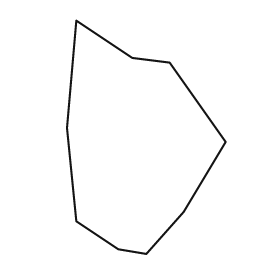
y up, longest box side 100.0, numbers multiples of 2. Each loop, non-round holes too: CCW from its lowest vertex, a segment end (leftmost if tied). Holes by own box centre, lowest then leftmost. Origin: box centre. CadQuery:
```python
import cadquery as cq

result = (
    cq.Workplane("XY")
    .moveTo(0.0, -50.0)
    .lineTo(16.0, -32.0)
    .lineTo(34.0, -2.0)
    .lineTo(10.0, 32.0)
    .lineTo(-6.0, 34.0)
    .lineTo(-30.0, 50.0)
    .lineTo(-34.0, 4.0)
    .lineTo(-30.0, -36.0)
    .lineTo(-12.0, -48.0)
    .close()
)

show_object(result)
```